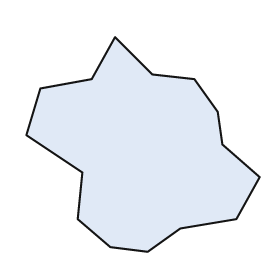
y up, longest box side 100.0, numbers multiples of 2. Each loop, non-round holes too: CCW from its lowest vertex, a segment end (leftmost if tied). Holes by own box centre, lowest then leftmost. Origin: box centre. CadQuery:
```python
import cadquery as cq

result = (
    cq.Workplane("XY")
    .moveTo(2.0, -46.0)
    .lineTo(16.0, -36.0)
    .lineTo(40.0, -32.0)
    .lineTo(50.0, -14.0)
    .lineTo(34.0, 0.0)
    .lineTo(32.0, 14.0)
    .lineTo(22.0, 28.0)
    .lineTo(4.0, 30.0)
    .lineTo(-12.0, 46.0)
    .lineTo(-22.0, 28.0)
    .lineTo(-44.0, 24.0)
    .lineTo(-50.0, 4.0)
    .lineTo(-26.0, -12.0)
    .lineTo(-28.0, -32.0)
    .lineTo(-14.0, -44.0)
    .close()
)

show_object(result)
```